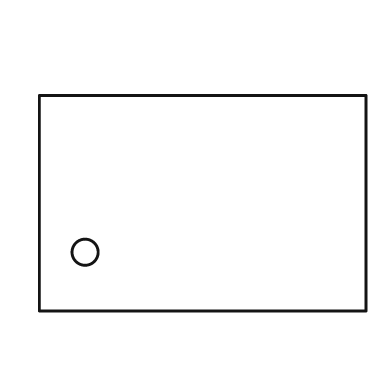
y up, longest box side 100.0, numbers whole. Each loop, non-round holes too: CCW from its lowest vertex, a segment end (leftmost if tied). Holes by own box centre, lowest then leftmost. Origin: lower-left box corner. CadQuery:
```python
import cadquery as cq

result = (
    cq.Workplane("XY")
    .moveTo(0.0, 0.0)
    .lineTo(100.0, 0.0)
    .lineTo(100.0, 66.0)
    .lineTo(0.0, 66.0)
    .close()
    .moveTo(14.0, 18.0)
    .circle(4.0)
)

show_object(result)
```